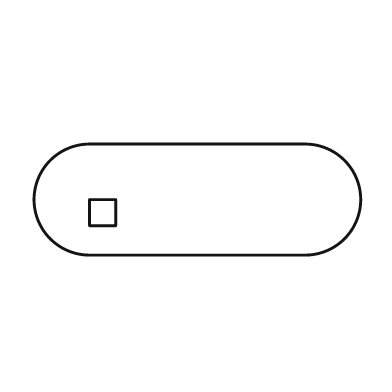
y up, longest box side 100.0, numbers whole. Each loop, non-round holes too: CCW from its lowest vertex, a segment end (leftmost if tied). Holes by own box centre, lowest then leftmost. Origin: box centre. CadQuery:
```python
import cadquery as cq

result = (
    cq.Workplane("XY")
    .moveTo(-33.0, -17.0)
    .lineTo(33.0, -17.0)
    .threePointArc((50.0, 0.0), (33.0, 17.0))
    .lineTo(-33.0, 17.0)
    .threePointArc((-50.0, 0.0), (-33.0, -17.0))
    .close()
    .moveTo(-33.0, -8.0)
    .lineTo(-25.0, -8.0)
    .lineTo(-25.0, 0.0)
    .lineTo(-33.0, 0.0)
    .close()
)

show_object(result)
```